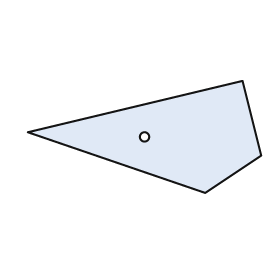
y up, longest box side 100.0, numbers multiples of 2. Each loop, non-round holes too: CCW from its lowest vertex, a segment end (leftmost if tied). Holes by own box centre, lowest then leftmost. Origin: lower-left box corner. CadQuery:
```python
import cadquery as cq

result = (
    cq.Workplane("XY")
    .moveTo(76.0, 0.0)
    .lineTo(100.0, 16.0)
    .lineTo(92.0, 48.0)
    .lineTo(0.0, 26.0)
    .close()
    .moveTo(50.0, 24.0)
    .circle(2.0)
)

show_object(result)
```